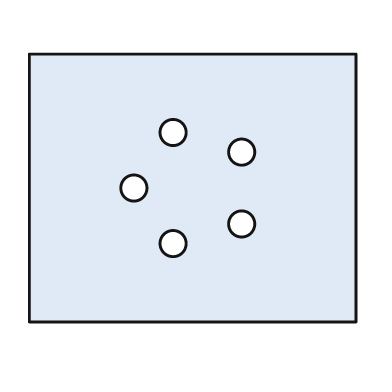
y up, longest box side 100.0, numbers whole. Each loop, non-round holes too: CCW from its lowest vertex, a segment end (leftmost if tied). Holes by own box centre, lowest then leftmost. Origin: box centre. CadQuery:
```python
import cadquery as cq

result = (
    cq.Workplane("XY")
    .moveTo(-50.0, -41.0)
    .lineTo(50.0, -41.0)
    .lineTo(50.0, 41.0)
    .lineTo(-50.0, 41.0)
    .close()
    .moveTo(-6.0, -17.0)
    .circle(4.0)
    .moveTo(15.0, -11.0)
    .circle(4.0)
    .moveTo(-18.0, 0.0)
    .circle(4.0)
    .moveTo(15.0, 11.0)
    .circle(4.0)
    .moveTo(-6.0, 17.0)
    .circle(4.0)
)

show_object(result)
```